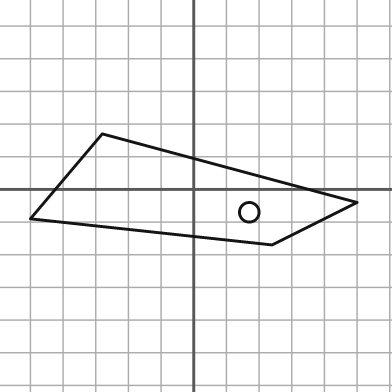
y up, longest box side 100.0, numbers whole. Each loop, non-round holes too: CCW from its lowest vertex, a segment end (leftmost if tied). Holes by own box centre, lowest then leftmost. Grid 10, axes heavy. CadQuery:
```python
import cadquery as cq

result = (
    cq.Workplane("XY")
    .moveTo(24.0, -17.0)
    .lineTo(50.0, -4.0)
    .lineTo(-28.0, 17.0)
    .lineTo(-50.0, -9.0)
    .close()
    .moveTo(17.0, -7.0)
    .circle(3.0)
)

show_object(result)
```